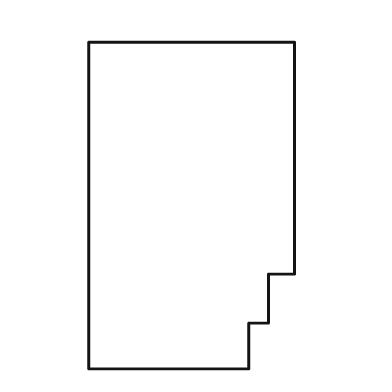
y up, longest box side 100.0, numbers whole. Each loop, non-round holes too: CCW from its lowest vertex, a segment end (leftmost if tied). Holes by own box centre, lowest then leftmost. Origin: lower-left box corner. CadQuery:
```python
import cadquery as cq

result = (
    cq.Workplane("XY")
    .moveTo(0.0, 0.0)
    .lineTo(49.0, 0.0)
    .lineTo(49.0, 14.0)
    .lineTo(55.0, 14.0)
    .lineTo(55.0, 29.0)
    .lineTo(63.0, 29.0)
    .lineTo(63.0, 100.0)
    .lineTo(0.0, 100.0)
    .close()
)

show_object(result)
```